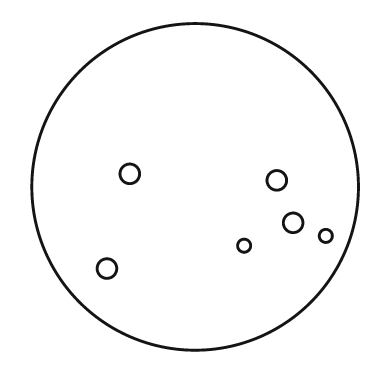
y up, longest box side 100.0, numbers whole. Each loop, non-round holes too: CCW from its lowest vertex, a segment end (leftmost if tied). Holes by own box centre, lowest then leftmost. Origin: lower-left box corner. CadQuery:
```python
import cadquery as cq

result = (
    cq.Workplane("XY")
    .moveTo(50.0, 50.0)
    .circle(50.0)
    .moveTo(23.0, 25.0)
    .circle(3.0)
    .moveTo(65.0, 32.0)
    .circle(2.0)
    .moveTo(90.0, 35.0)
    .circle(2.0)
    .moveTo(80.0, 39.0)
    .circle(3.0)
    .moveTo(75.0, 52.0)
    .circle(3.0)
    .moveTo(30.0, 54.0)
    .circle(3.0)
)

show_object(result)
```